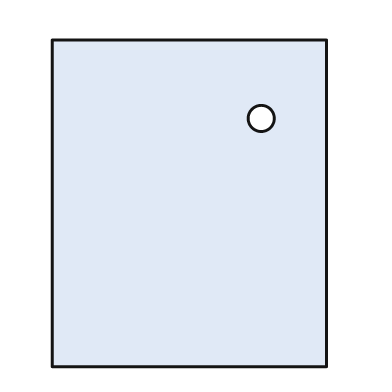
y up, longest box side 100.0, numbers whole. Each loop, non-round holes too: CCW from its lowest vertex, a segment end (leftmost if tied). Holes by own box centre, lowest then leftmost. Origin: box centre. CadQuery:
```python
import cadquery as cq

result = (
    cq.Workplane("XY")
    .moveTo(-42.0, -50.0)
    .lineTo(42.0, -50.0)
    .lineTo(42.0, 50.0)
    .lineTo(-42.0, 50.0)
    .close()
    .moveTo(22.0, 26.0)
    .circle(4.0)
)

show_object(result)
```